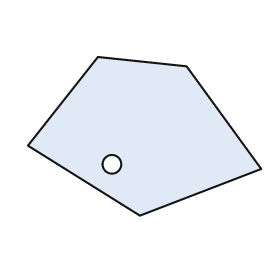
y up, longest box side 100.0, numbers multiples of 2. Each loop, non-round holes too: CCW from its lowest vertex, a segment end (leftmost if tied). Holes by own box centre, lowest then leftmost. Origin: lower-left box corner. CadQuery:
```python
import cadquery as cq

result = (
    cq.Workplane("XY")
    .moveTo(48.0, 0.0)
    .lineTo(100.0, 20.0)
    .lineTo(68.0, 64.0)
    .lineTo(30.0, 68.0)
    .lineTo(0.0, 30.0)
    .close()
    .moveTo(36.0, 22.0)
    .circle(4.0)
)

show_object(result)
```